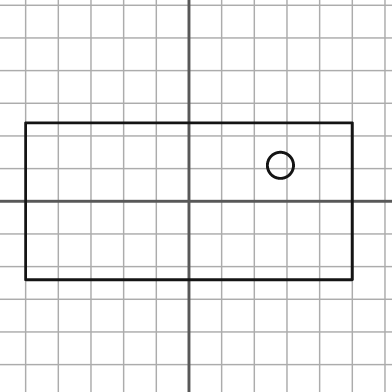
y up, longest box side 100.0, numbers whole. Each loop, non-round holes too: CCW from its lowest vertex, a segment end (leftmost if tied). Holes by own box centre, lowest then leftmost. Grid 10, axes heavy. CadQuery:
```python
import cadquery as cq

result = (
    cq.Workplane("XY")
    .moveTo(-50.0, -24.0)
    .lineTo(50.0, -24.0)
    .lineTo(50.0, 24.0)
    .lineTo(-50.0, 24.0)
    .close()
    .moveTo(28.0, 11.0)
    .circle(4.0)
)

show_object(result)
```